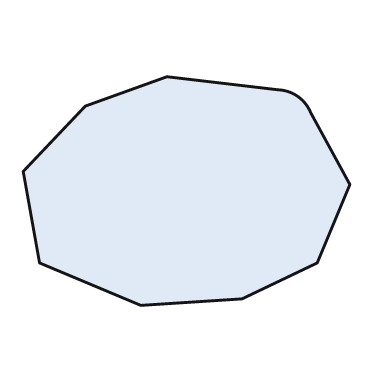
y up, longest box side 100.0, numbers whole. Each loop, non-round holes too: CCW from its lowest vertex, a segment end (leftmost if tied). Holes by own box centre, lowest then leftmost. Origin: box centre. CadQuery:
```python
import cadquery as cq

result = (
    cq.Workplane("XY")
    .moveTo(-14.0, -35.0)
    .lineTo(17.0, -33.0)
    .lineTo(40.0, -22.0)
    .lineTo(50.0, 2.0)
    .lineTo(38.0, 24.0)
    .threePointArc((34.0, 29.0), (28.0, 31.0))
    .lineTo(-6.0, 35.0)
    .lineTo(-31.0, 26.0)
    .lineTo(-50.0, 6.0)
    .lineTo(-45.0, -22.0)
    .close()
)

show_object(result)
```